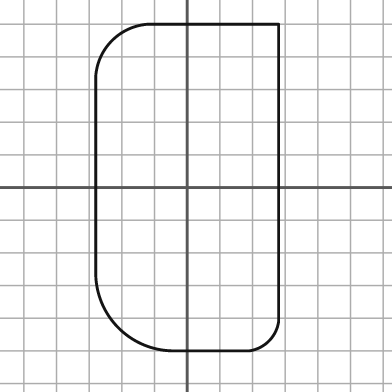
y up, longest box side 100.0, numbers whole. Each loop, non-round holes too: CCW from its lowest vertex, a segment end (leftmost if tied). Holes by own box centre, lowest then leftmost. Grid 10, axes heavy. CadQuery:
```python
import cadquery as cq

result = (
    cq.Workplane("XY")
    .moveTo(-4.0, -50.0)
    .lineTo(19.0, -50.0)
    .threePointArc((25.0, -47.0), (28.0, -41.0))
    .lineTo(28.0, 50.0)
    .lineTo(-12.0, 50.0)
    .threePointArc((-23.0, 45.0), (-28.0, 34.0))
    .lineTo(-28.0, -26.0)
    .threePointArc((-21.0, -43.0), (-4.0, -50.0))
    .close()
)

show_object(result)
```